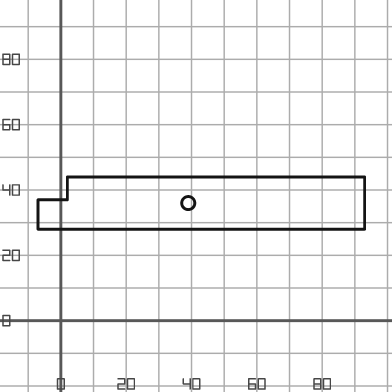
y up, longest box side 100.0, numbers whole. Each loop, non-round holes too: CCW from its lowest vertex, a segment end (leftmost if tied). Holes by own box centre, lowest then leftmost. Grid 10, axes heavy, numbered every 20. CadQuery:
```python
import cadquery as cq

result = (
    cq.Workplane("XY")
    .moveTo(-7.0, 28.0)
    .lineTo(93.0, 28.0)
    .lineTo(93.0, 44.0)
    .lineTo(2.0, 44.0)
    .lineTo(2.0, 37.0)
    .lineTo(-7.0, 37.0)
    .close()
    .moveTo(39.0, 36.0)
    .circle(2.0)
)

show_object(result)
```